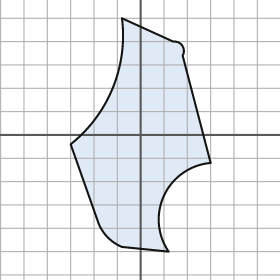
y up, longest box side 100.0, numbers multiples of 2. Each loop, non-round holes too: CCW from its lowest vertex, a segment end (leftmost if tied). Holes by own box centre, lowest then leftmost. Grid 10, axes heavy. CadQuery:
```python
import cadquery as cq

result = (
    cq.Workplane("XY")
    .moveTo(12.0, -50.0)
    .threePointArc((10.0, -26.0), (30.0, -12.0))
    .lineTo(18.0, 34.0)
    .threePointArc((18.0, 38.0), (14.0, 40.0))
    .lineTo(-8.0, 50.0)
    .threePointArc((-12.0, 20.0), (-30.0, -4.0))
    .lineTo(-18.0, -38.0)
    .threePointArc((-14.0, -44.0), (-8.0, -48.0))
    .close()
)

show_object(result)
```